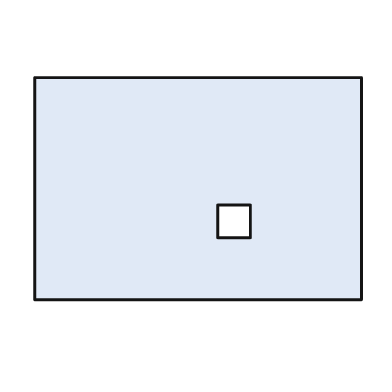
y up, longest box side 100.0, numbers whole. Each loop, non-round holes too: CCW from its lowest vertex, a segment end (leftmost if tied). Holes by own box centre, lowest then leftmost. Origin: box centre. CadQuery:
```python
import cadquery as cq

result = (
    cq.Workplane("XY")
    .moveTo(-50.0, -34.0)
    .lineTo(50.0, -34.0)
    .lineTo(50.0, 34.0)
    .lineTo(-50.0, 34.0)
    .close()
    .moveTo(6.0, -15.0)
    .lineTo(16.0, -15.0)
    .lineTo(16.0, -5.0)
    .lineTo(6.0, -5.0)
    .close()
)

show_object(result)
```